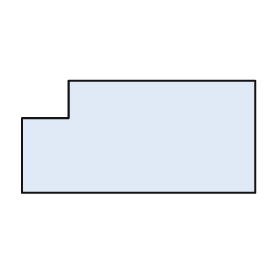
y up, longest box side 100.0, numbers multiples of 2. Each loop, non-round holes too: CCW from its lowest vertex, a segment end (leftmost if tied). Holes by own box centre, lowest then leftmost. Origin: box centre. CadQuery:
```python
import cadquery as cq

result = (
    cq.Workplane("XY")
    .moveTo(-50.0, -24.0)
    .lineTo(50.0, -24.0)
    .lineTo(50.0, 24.0)
    .lineTo(-30.0, 24.0)
    .lineTo(-30.0, 8.0)
    .lineTo(-50.0, 8.0)
    .close()
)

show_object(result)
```